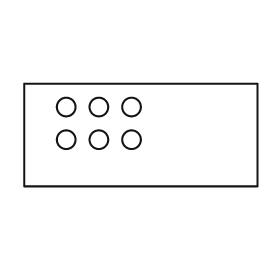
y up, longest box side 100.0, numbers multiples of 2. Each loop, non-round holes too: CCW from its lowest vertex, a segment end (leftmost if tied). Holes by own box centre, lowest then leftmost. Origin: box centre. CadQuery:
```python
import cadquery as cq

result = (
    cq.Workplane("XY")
    .moveTo(-50.0, -22.0)
    .lineTo(50.0, -22.0)
    .lineTo(50.0, 22.0)
    .lineTo(-50.0, 22.0)
    .close()
    .moveTo(-32.0, -2.0)
    .circle(4.0)
    .moveTo(-18.0, -2.0)
    .circle(4.0)
    .moveTo(-4.0, -2.0)
    .circle(4.0)
    .moveTo(-32.0, 12.0)
    .circle(4.0)
    .moveTo(-18.0, 12.0)
    .circle(4.0)
    .moveTo(-4.0, 12.0)
    .circle(4.0)
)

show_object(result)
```